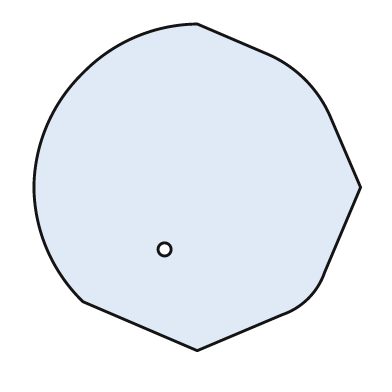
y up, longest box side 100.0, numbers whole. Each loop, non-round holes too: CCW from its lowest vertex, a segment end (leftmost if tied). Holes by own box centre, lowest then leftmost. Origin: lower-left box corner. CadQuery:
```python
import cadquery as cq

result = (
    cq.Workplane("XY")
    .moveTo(50.0, 0.0)
    .lineTo(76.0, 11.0)
    .threePointArc((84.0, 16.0), (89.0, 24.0))
    .lineTo(100.0, 50.0)
    .lineTo(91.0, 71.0)
    .threePointArc((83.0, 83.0), (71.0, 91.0))
    .lineTo(50.0, 100.0)
    .threePointArc((31.0, 96.0), (15.0, 85.0))
    .threePointArc((4.0, 69.0), (0.0, 50.0))
    .threePointArc((4.0, 31.0), (15.0, 15.0))
    .close()
    .moveTo(40.0, 31.0)
    .circle(2.0)
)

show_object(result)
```